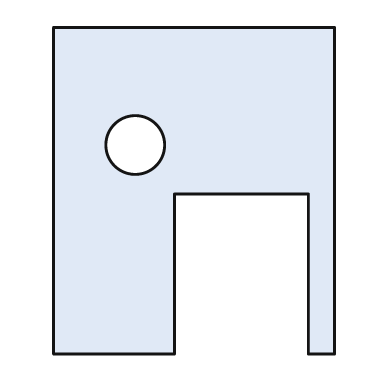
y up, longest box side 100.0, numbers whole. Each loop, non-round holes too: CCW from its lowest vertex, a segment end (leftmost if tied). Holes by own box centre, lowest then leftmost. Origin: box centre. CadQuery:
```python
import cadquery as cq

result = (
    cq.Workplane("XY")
    .moveTo(-43.0, -50.0)
    .lineTo(-6.0, -50.0)
    .lineTo(-6.0, -1.0)
    .lineTo(35.0, -1.0)
    .lineTo(35.0, -50.0)
    .lineTo(43.0, -50.0)
    .lineTo(43.0, 50.0)
    .lineTo(-43.0, 50.0)
    .close()
    .moveTo(-18.0, 14.0)
    .circle(9.0)
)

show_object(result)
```